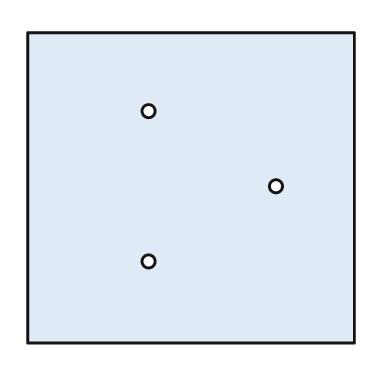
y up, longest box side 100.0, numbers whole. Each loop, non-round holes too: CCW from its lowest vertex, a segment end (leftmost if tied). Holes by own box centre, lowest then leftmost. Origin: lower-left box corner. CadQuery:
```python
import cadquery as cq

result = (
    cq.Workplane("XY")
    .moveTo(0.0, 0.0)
    .lineTo(100.0, 0.0)
    .lineTo(100.0, 95.0)
    .lineTo(0.0, 95.0)
    .close()
    .moveTo(37.0, 25.0)
    .circle(2.0)
    .moveTo(76.0, 48.0)
    .circle(2.0)
    .moveTo(37.0, 71.0)
    .circle(2.0)
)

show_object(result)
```